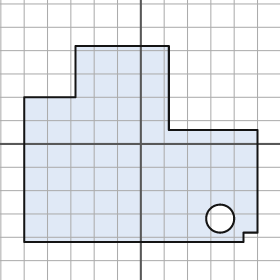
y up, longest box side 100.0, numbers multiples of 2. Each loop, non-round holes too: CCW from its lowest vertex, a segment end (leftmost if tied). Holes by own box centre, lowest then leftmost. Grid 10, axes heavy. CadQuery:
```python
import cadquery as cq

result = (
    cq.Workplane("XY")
    .moveTo(-50.0, -42.0)
    .lineTo(44.0, -42.0)
    .lineTo(44.0, -38.0)
    .lineTo(50.0, -38.0)
    .lineTo(50.0, 6.0)
    .lineTo(12.0, 6.0)
    .lineTo(12.0, 42.0)
    .lineTo(-28.0, 42.0)
    .lineTo(-28.0, 20.0)
    .lineTo(-50.0, 20.0)
    .close()
    .moveTo(34.0, -32.0)
    .circle(6.0)
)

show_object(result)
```